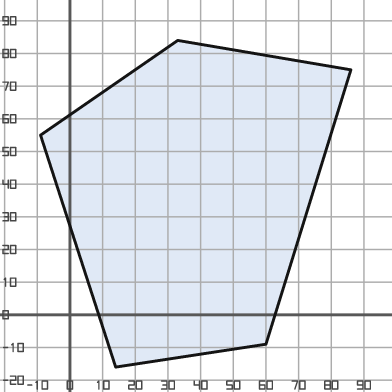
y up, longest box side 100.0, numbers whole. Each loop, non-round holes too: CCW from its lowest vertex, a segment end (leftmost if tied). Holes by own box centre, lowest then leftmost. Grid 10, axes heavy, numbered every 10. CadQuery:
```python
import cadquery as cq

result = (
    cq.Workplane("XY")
    .moveTo(14.0, -16.0)
    .lineTo(60.0, -9.0)
    .lineTo(86.0, 75.0)
    .lineTo(33.0, 84.0)
    .lineTo(-9.0, 55.0)
    .close()
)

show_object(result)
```